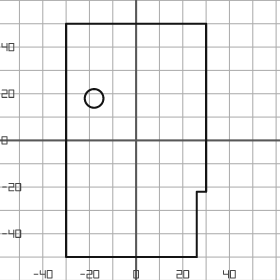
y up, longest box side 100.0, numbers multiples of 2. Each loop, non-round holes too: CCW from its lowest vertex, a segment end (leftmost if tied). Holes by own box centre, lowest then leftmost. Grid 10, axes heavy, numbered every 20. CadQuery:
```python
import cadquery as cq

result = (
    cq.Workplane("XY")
    .moveTo(-30.0, -50.0)
    .lineTo(26.0, -50.0)
    .lineTo(26.0, -22.0)
    .lineTo(30.0, -22.0)
    .lineTo(30.0, 50.0)
    .lineTo(-30.0, 50.0)
    .close()
    .moveTo(-18.0, 18.0)
    .circle(4.0)
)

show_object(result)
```